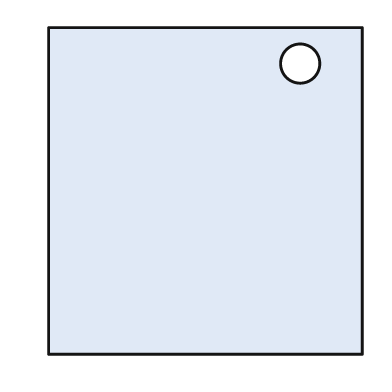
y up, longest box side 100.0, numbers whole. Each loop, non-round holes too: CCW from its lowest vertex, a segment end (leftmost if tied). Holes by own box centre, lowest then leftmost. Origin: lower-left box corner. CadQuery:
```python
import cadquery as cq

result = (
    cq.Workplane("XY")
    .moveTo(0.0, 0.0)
    .lineTo(96.0, 0.0)
    .lineTo(96.0, 100.0)
    .lineTo(0.0, 100.0)
    .close()
    .moveTo(77.0, 89.0)
    .circle(6.0)
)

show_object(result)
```